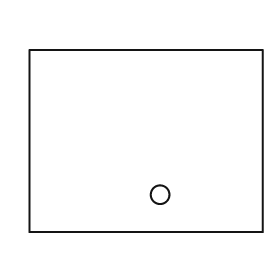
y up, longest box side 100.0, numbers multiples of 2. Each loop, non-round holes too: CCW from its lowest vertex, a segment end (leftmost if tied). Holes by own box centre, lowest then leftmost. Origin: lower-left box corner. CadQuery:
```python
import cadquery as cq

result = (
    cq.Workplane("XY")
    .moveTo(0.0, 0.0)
    .lineTo(100.0, 0.0)
    .lineTo(100.0, 78.0)
    .lineTo(0.0, 78.0)
    .close()
    .moveTo(56.0, 16.0)
    .circle(4.0)
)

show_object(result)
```